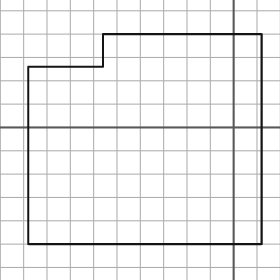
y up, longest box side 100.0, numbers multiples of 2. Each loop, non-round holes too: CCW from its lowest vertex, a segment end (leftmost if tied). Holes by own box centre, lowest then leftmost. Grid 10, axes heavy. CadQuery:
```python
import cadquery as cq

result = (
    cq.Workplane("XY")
    .moveTo(-88.0, -50.0)
    .lineTo(12.0, -50.0)
    .lineTo(12.0, 40.0)
    .lineTo(-56.0, 40.0)
    .lineTo(-56.0, 26.0)
    .lineTo(-88.0, 26.0)
    .close()
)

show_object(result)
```